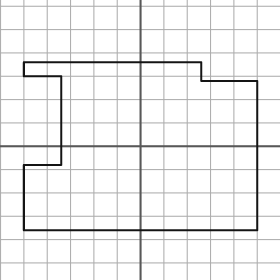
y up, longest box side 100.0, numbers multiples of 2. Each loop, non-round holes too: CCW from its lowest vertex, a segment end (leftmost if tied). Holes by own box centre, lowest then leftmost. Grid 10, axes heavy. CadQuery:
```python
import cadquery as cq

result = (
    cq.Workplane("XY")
    .moveTo(-50.0, -36.0)
    .lineTo(50.0, -36.0)
    .lineTo(50.0, 28.0)
    .lineTo(26.0, 28.0)
    .lineTo(26.0, 36.0)
    .lineTo(-50.0, 36.0)
    .lineTo(-50.0, 30.0)
    .lineTo(-34.0, 30.0)
    .lineTo(-34.0, -8.0)
    .lineTo(-50.0, -8.0)
    .close()
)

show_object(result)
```